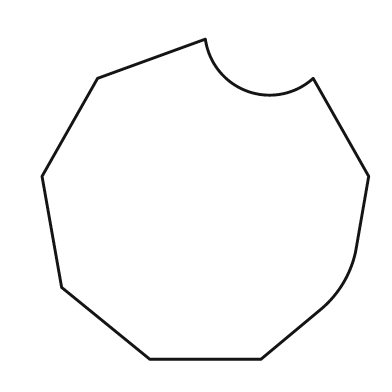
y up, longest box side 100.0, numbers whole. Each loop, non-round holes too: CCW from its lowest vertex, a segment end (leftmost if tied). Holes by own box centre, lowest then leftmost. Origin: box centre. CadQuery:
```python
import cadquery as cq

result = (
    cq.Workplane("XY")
    .moveTo(-17.0, -49.0)
    .lineTo(17.0, -49.0)
    .lineTo(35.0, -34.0)
    .threePointArc((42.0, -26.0), (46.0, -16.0))
    .lineTo(50.0, 7.0)
    .lineTo(33.0, 37.0)
    .threePointArc((13.0, 33.0), (0.0, 49.0))
    .lineTo(-33.0, 37.0)
    .lineTo(-50.0, 7.0)
    .lineTo(-44.0, -27.0)
    .close()
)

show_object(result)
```